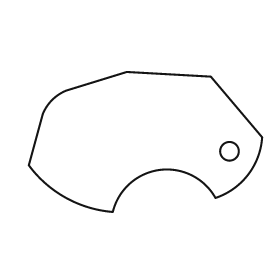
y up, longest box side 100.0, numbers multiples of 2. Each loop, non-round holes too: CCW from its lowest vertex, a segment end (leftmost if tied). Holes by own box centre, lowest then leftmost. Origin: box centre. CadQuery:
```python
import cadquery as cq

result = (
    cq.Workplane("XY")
    .moveTo(-14.0, -30.0)
    .threePointArc((6.0, -12.0), (30.0, -24.0))
    .threePointArc((44.0, -14.0), (50.0, 2.0))
    .lineTo(28.0, 28.0)
    .lineTo(-8.0, 30.0)
    .lineTo(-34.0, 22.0)
    .threePointArc((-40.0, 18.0), (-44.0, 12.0))
    .lineTo(-50.0, -10.0)
    .threePointArc((-34.0, -24.0), (-14.0, -30.0))
    .close()
    .moveTo(36.0, -4.0)
    .circle(4.0)
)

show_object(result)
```